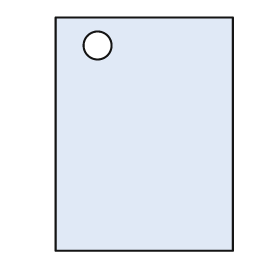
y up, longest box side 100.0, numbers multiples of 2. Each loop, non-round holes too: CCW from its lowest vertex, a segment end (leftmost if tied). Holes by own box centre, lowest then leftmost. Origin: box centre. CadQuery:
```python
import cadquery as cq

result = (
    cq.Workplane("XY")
    .moveTo(-38.0, -50.0)
    .lineTo(38.0, -50.0)
    .lineTo(38.0, 50.0)
    .lineTo(-38.0, 50.0)
    .close()
    .moveTo(-20.0, 38.0)
    .circle(6.0)
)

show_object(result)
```